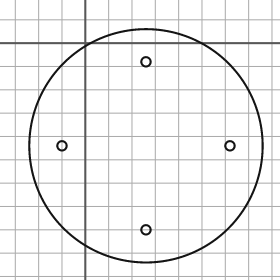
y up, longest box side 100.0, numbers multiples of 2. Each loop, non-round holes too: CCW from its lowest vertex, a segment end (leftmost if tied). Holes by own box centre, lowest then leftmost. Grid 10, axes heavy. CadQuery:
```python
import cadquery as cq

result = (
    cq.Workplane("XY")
    .moveTo(26.0, -44.0)
    .circle(50.0)
    .moveTo(26.0, -80.0)
    .circle(2.0)
    .moveTo(-10.0, -44.0)
    .circle(2.0)
    .moveTo(62.0, -44.0)
    .circle(2.0)
    .moveTo(26.0, -8.0)
    .circle(2.0)
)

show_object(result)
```